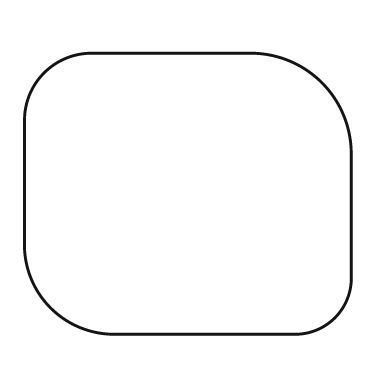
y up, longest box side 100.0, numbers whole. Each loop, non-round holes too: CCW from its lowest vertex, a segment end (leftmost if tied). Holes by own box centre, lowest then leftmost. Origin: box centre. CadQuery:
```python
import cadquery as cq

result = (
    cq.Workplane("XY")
    .moveTo(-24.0, -43.0)
    .lineTo(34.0, -43.0)
    .threePointArc((45.0, -38.0), (50.0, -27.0))
    .lineTo(50.0, 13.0)
    .threePointArc((41.0, 34.0), (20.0, 43.0))
    .lineTo(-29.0, 43.0)
    .threePointArc((-44.0, 37.0), (-50.0, 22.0))
    .lineTo(-50.0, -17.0)
    .threePointArc((-42.0, -35.0), (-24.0, -43.0))
    .close()
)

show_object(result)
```